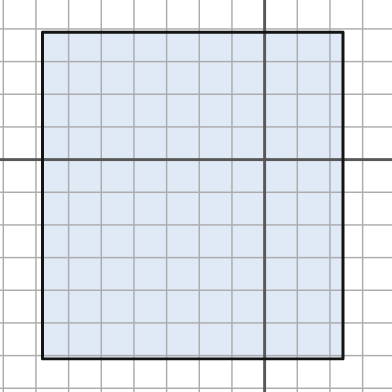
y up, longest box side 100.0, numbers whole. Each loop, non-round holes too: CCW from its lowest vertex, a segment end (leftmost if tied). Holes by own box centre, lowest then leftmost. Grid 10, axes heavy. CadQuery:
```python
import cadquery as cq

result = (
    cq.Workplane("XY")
    .moveTo(-68.0, -61.0)
    .lineTo(24.0, -61.0)
    .lineTo(24.0, 39.0)
    .lineTo(-68.0, 39.0)
    .close()
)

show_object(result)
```